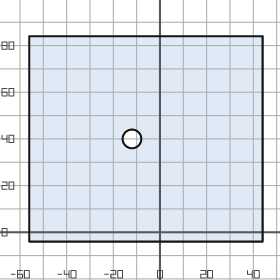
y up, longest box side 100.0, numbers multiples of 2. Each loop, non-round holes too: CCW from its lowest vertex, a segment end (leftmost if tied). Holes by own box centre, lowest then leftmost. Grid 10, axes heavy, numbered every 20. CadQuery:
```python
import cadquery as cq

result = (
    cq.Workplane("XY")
    .moveTo(-56.0, -4.0)
    .lineTo(44.0, -4.0)
    .lineTo(44.0, 84.0)
    .lineTo(-56.0, 84.0)
    .close()
    .moveTo(-12.0, 40.0)
    .circle(4.0)
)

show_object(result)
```